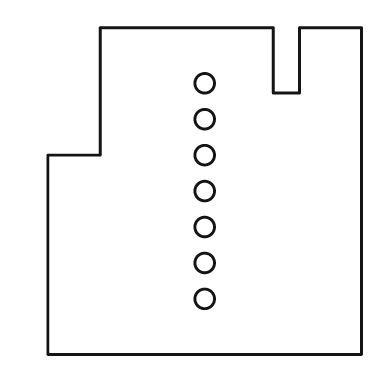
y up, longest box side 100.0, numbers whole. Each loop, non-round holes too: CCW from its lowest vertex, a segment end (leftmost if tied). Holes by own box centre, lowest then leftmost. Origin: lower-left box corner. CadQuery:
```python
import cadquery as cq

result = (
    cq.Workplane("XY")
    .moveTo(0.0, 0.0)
    .lineTo(96.0, 0.0)
    .lineTo(96.0, 100.0)
    .lineTo(77.0, 100.0)
    .lineTo(77.0, 80.0)
    .lineTo(69.0, 80.0)
    .lineTo(69.0, 100.0)
    .lineTo(16.0, 100.0)
    .lineTo(16.0, 61.0)
    .lineTo(0.0, 61.0)
    .close()
    .moveTo(48.0, 17.0)
    .circle(3.0)
    .moveTo(48.0, 28.0)
    .circle(3.0)
    .moveTo(48.0, 39.0)
    .circle(3.0)
    .moveTo(48.0, 50.0)
    .circle(3.0)
    .moveTo(48.0, 61.0)
    .circle(3.0)
    .moveTo(48.0, 72.0)
    .circle(3.0)
    .moveTo(48.0, 83.0)
    .circle(3.0)
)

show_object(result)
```